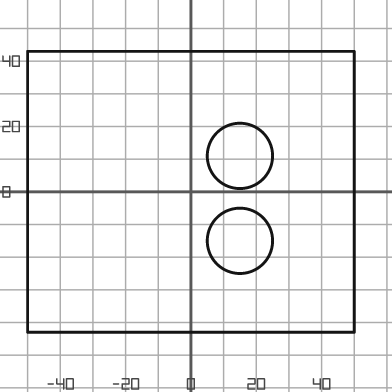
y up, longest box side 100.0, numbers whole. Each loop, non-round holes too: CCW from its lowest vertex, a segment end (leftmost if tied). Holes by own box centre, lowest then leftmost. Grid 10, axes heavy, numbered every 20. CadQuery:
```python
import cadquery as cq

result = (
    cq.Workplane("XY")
    .moveTo(-50.0, -43.0)
    .lineTo(50.0, -43.0)
    .lineTo(50.0, 43.0)
    .lineTo(-50.0, 43.0)
    .close()
    .moveTo(15.0, -15.0)
    .circle(10.0)
    .moveTo(15.0, 11.0)
    .circle(10.0)
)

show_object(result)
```